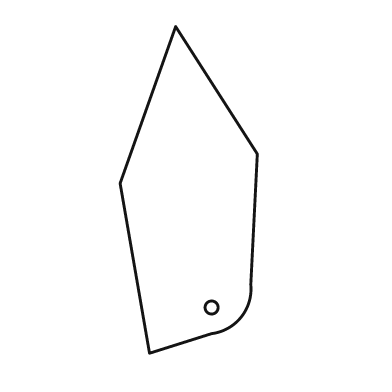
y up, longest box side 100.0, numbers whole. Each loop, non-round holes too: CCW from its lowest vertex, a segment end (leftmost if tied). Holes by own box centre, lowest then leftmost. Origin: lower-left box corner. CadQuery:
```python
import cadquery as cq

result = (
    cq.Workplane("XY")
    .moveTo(9.0, 0.0)
    .lineTo(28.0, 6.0)
    .threePointArc((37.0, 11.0), (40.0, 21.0))
    .lineTo(42.0, 61.0)
    .lineTo(17.0, 100.0)
    .lineTo(0.0, 52.0)
    .close()
    .moveTo(28.0, 14.0)
    .circle(2.0)
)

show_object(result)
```